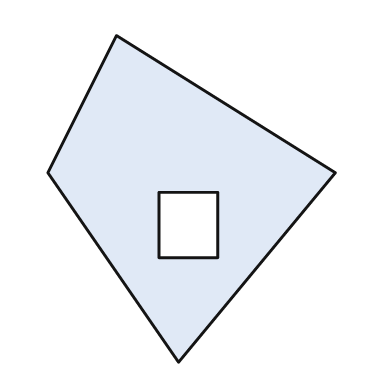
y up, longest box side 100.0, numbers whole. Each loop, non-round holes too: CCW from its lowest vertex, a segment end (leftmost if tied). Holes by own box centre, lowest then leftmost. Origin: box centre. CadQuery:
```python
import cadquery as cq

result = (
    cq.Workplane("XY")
    .moveTo(-4.0, -50.0)
    .lineTo(44.0, 8.0)
    .lineTo(-23.0, 50.0)
    .lineTo(-44.0, 8.0)
    .close()
    .moveTo(-10.0, -18.0)
    .lineTo(8.0, -18.0)
    .lineTo(8.0, 2.0)
    .lineTo(-10.0, 2.0)
    .close()
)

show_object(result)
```